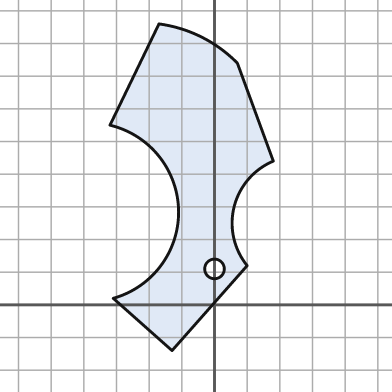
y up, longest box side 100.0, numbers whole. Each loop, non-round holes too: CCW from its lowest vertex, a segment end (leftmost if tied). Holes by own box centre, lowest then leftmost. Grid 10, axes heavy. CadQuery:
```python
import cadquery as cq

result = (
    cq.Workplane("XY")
    .moveTo(-13.0, -14.0)
    .lineTo(10.0, 12.0)
    .threePointArc((6.0, 30.0), (18.0, 44.0))
    .lineTo(7.0, 74.0)
    .threePointArc((-4.0, 82.0), (-17.0, 86.0))
    .lineTo(-32.0, 55.0)
    .threePointArc((-11.0, 29.0), (-31.0, 2.0))
    .close()
    .moveTo(0.0, 11.0)
    .circle(3.0)
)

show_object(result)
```